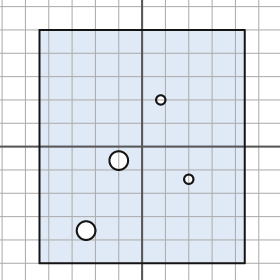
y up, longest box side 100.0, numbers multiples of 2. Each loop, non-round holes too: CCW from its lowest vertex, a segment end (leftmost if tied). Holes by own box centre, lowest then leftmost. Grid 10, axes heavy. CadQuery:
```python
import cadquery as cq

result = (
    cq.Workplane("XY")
    .moveTo(-44.0, -50.0)
    .lineTo(44.0, -50.0)
    .lineTo(44.0, 50.0)
    .lineTo(-44.0, 50.0)
    .close()
    .moveTo(-24.0, -36.0)
    .circle(4.0)
    .moveTo(20.0, -14.0)
    .circle(2.0)
    .moveTo(-10.0, -6.0)
    .circle(4.0)
    .moveTo(8.0, 20.0)
    .circle(2.0)
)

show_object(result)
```